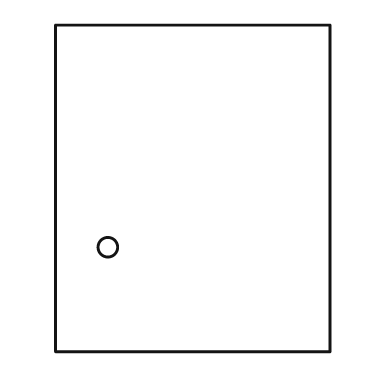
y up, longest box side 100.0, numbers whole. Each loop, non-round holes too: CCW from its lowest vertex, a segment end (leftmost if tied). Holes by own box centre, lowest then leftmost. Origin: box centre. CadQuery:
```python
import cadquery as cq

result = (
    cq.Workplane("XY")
    .moveTo(-42.0, -50.0)
    .lineTo(42.0, -50.0)
    .lineTo(42.0, 50.0)
    .lineTo(-42.0, 50.0)
    .close()
    .moveTo(-26.0, -18.0)
    .circle(3.0)
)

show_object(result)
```